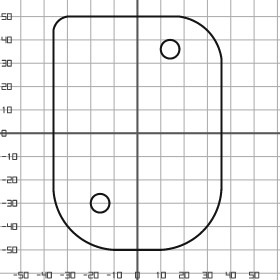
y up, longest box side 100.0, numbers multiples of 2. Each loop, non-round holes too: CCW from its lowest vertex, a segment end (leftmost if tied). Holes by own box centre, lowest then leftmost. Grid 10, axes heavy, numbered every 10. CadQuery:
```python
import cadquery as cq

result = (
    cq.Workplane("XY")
    .moveTo(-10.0, -50.0)
    .lineTo(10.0, -50.0)
    .threePointArc((28.0, -42.0), (36.0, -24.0))
    .lineTo(36.0, 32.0)
    .threePointArc((30.0, 44.0), (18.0, 50.0))
    .lineTo(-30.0, 50.0)
    .threePointArc((-34.0, 48.0), (-36.0, 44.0))
    .lineTo(-36.0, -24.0)
    .threePointArc((-28.0, -42.0), (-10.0, -50.0))
    .close()
    .moveTo(-16.0, -30.0)
    .circle(4.0)
    .moveTo(14.0, 36.0)
    .circle(4.0)
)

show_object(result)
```